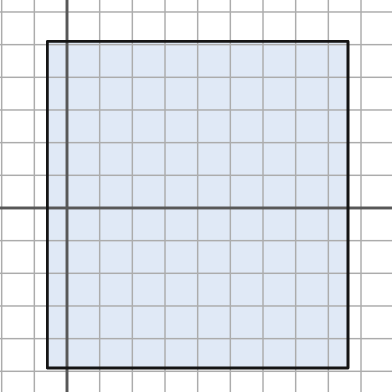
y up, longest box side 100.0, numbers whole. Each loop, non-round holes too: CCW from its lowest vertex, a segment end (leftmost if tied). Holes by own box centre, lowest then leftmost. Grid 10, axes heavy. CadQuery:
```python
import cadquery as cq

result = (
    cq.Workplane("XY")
    .moveTo(-6.0, -49.0)
    .lineTo(86.0, -49.0)
    .lineTo(86.0, 51.0)
    .lineTo(-6.0, 51.0)
    .close()
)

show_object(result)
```